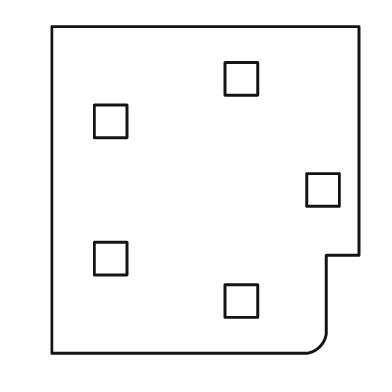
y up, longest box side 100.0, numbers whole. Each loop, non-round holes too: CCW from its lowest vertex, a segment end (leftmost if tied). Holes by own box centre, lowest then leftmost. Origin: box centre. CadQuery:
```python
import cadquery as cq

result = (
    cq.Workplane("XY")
    .moveTo(-47.0, -50.0)
    .lineTo(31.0, -50.0)
    .threePointArc((35.0, -48.0), (37.0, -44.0))
    .lineTo(37.0, -20.0)
    .lineTo(47.0, -20.0)
    .lineTo(47.0, 50.0)
    .lineTo(-47.0, 50.0)
    .close()
    .moveTo(6.0, -39.0)
    .lineTo(16.0, -39.0)
    .lineTo(16.0, -29.0)
    .lineTo(6.0, -29.0)
    .close()
    .moveTo(-34.0, -26.0)
    .lineTo(-24.0, -26.0)
    .lineTo(-24.0, -16.0)
    .lineTo(-34.0, -16.0)
    .close()
    .moveTo(31.0, -5.0)
    .lineTo(41.0, -5.0)
    .lineTo(41.0, 5.0)
    .lineTo(31.0, 5.0)
    .close()
    .moveTo(-34.0, 16.0)
    .lineTo(-24.0, 16.0)
    .lineTo(-24.0, 26.0)
    .lineTo(-34.0, 26.0)
    .close()
    .moveTo(6.0, 29.0)
    .lineTo(16.0, 29.0)
    .lineTo(16.0, 39.0)
    .lineTo(6.0, 39.0)
    .close()
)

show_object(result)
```